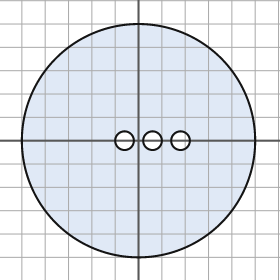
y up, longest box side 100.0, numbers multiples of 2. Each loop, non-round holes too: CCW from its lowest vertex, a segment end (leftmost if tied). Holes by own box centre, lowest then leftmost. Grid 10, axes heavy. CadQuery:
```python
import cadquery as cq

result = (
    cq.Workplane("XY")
    .moveTo(0.0, 0.0)
    .circle(50.0)
    .moveTo(-6.0, 0.0)
    .circle(4.0)
    .moveTo(6.0, 0.0)
    .circle(4.0)
    .moveTo(18.0, 0.0)
    .circle(4.0)
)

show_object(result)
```